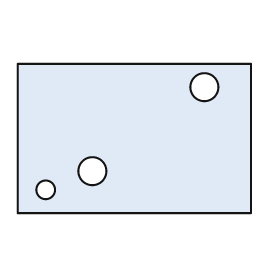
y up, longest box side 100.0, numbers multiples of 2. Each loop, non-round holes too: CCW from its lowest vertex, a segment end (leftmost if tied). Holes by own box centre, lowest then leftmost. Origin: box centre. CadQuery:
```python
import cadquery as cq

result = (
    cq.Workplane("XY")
    .moveTo(-50.0, -32.0)
    .lineTo(50.0, -32.0)
    .lineTo(50.0, 32.0)
    .lineTo(-50.0, 32.0)
    .close()
    .moveTo(-38.0, -22.0)
    .circle(4.0)
    .moveTo(-18.0, -14.0)
    .circle(6.0)
    .moveTo(30.0, 22.0)
    .circle(6.0)
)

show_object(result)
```